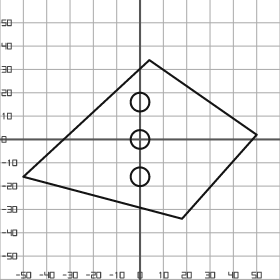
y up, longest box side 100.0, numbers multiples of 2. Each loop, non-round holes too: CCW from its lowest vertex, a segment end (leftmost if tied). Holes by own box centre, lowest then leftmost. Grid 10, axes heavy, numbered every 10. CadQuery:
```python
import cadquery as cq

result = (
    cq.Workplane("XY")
    .moveTo(18.0, -34.0)
    .lineTo(50.0, 2.0)
    .lineTo(4.0, 34.0)
    .lineTo(-50.0, -16.0)
    .close()
    .moveTo(0.0, -16.0)
    .circle(4.0)
    .moveTo(0.0, 0.0)
    .circle(4.0)
    .moveTo(0.0, 16.0)
    .circle(4.0)
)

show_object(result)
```